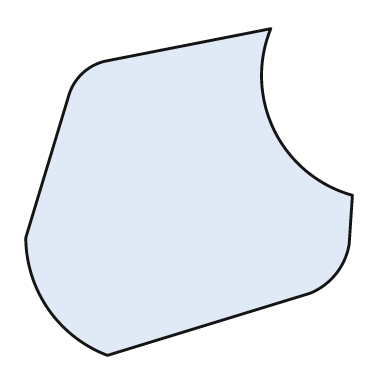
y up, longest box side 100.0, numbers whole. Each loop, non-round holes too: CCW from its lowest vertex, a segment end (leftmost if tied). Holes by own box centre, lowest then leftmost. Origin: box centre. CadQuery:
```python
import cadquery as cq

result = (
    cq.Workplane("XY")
    .moveTo(-25.0, -50.0)
    .lineTo(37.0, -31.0)
    .threePointArc((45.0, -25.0), (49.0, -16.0))
    .lineTo(50.0, -1.0)
    .threePointArc((26.0, 19.0), (25.0, 50.0))
    .lineTo(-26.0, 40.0)
    .threePointArc((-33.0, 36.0), (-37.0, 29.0))
    .lineTo(-50.0, -14.0)
    .threePointArc((-43.0, -36.0), (-25.0, -50.0))
    .close()
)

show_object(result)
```